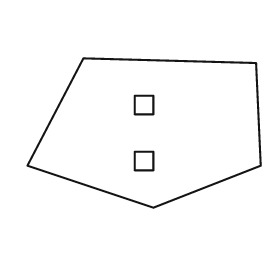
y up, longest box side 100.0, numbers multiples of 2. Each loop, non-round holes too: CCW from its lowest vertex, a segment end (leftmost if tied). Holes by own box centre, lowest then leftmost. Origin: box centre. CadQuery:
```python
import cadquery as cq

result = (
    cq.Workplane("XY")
    .moveTo(4.0, -32.0)
    .lineTo(50.0, -14.0)
    .lineTo(48.0, 30.0)
    .lineTo(-26.0, 32.0)
    .lineTo(-50.0, -14.0)
    .close()
    .moveTo(-4.0, -16.0)
    .lineTo(4.0, -16.0)
    .lineTo(4.0, -8.0)
    .lineTo(-4.0, -8.0)
    .close()
    .moveTo(-4.0, 8.0)
    .lineTo(4.0, 8.0)
    .lineTo(4.0, 16.0)
    .lineTo(-4.0, 16.0)
    .close()
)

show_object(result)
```